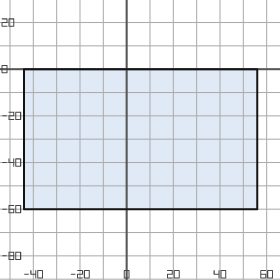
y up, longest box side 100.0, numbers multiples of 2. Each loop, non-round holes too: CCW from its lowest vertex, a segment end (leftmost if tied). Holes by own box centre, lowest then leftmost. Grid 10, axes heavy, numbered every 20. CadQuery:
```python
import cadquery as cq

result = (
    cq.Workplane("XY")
    .moveTo(-44.0, -60.0)
    .lineTo(56.0, -60.0)
    .lineTo(56.0, 0.0)
    .lineTo(-44.0, 0.0)
    .close()
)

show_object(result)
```